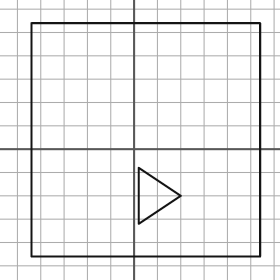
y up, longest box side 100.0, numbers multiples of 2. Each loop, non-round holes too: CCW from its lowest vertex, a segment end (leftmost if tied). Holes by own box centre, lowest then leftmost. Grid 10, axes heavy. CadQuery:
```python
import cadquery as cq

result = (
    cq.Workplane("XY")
    .moveTo(-44.0, -46.0)
    .lineTo(54.0, -46.0)
    .lineTo(54.0, 54.0)
    .lineTo(-44.0, 54.0)
    .close()
    .moveTo(2.0, -32.0)
    .lineTo(20.0, -20.0)
    .lineTo(2.0, -8.0)
    .close()
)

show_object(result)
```